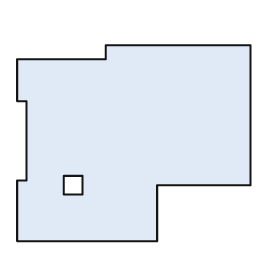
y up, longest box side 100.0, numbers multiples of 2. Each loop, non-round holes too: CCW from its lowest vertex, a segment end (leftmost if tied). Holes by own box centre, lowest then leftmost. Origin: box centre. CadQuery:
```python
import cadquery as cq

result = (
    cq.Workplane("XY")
    .moveTo(-50.0, -42.0)
    .lineTo(10.0, -42.0)
    .lineTo(10.0, -18.0)
    .lineTo(50.0, -18.0)
    .lineTo(50.0, 42.0)
    .lineTo(-12.0, 42.0)
    .lineTo(-12.0, 36.0)
    .lineTo(-50.0, 36.0)
    .lineTo(-50.0, 18.0)
    .lineTo(-46.0, 18.0)
    .lineTo(-46.0, -16.0)
    .lineTo(-50.0, -16.0)
    .close()
    .moveTo(-30.0, -22.0)
    .lineTo(-22.0, -22.0)
    .lineTo(-22.0, -14.0)
    .lineTo(-30.0, -14.0)
    .close()
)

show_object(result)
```